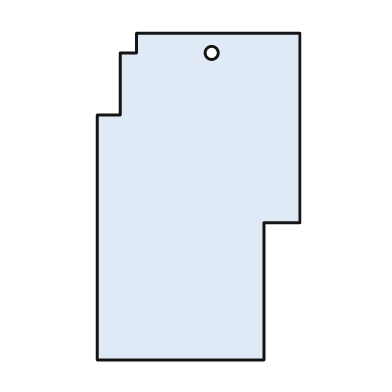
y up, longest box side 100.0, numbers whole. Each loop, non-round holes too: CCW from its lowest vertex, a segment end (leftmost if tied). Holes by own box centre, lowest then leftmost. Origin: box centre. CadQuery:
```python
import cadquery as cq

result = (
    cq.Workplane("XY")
    .moveTo(-31.0, -50.0)
    .lineTo(20.0, -50.0)
    .lineTo(20.0, -8.0)
    .lineTo(31.0, -8.0)
    .lineTo(31.0, 50.0)
    .lineTo(-19.0, 50.0)
    .lineTo(-19.0, 44.0)
    .lineTo(-24.0, 44.0)
    .lineTo(-24.0, 25.0)
    .lineTo(-31.0, 25.0)
    .close()
    .moveTo(4.0, 44.0)
    .circle(2.0)
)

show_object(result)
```